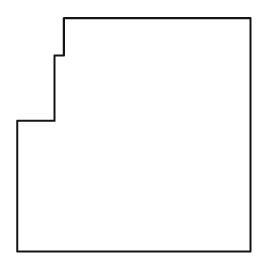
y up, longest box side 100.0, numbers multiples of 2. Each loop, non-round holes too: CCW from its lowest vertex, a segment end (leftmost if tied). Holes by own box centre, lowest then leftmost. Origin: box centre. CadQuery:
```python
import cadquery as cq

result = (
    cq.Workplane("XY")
    .moveTo(-50.0, -50.0)
    .lineTo(50.0, -50.0)
    .lineTo(50.0, 50.0)
    .lineTo(-30.0, 50.0)
    .lineTo(-30.0, 34.0)
    .lineTo(-34.0, 34.0)
    .lineTo(-34.0, 6.0)
    .lineTo(-50.0, 6.0)
    .close()
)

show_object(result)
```